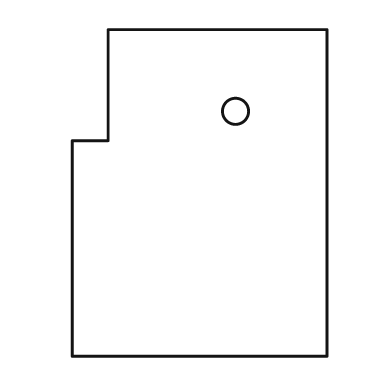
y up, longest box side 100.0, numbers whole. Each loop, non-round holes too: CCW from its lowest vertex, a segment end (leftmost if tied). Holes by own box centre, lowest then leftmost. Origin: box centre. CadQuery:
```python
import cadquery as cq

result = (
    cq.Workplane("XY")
    .moveTo(-39.0, -50.0)
    .lineTo(39.0, -50.0)
    .lineTo(39.0, 50.0)
    .lineTo(-28.0, 50.0)
    .lineTo(-28.0, 16.0)
    .lineTo(-39.0, 16.0)
    .close()
    .moveTo(11.0, 25.0)
    .circle(4.0)
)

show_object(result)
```